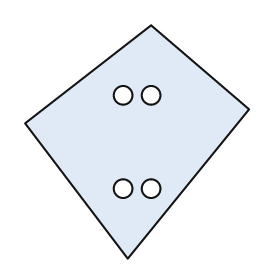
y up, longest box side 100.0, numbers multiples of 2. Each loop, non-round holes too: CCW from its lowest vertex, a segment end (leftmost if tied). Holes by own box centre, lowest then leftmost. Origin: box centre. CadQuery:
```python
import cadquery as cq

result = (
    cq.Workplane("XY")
    .moveTo(-4.0, -50.0)
    .lineTo(48.0, 14.0)
    .lineTo(6.0, 50.0)
    .lineTo(-48.0, 8.0)
    .close()
    .moveTo(-6.0, -20.0)
    .circle(4.0)
    .moveTo(6.0, -20.0)
    .circle(4.0)
    .moveTo(-6.0, 20.0)
    .circle(4.0)
    .moveTo(6.0, 20.0)
    .circle(4.0)
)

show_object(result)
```